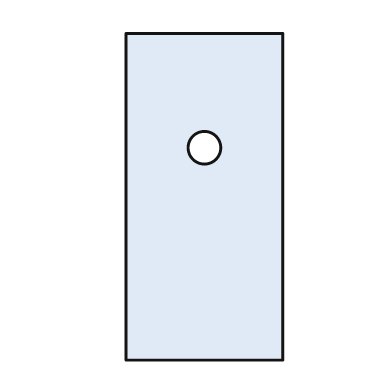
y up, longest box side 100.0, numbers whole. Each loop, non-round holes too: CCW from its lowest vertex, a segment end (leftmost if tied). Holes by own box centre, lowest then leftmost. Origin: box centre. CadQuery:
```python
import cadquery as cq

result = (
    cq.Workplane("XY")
    .moveTo(-24.0, -50.0)
    .lineTo(24.0, -50.0)
    .lineTo(24.0, 50.0)
    .lineTo(-24.0, 50.0)
    .close()
    .moveTo(0.0, 15.0)
    .circle(5.0)
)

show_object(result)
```